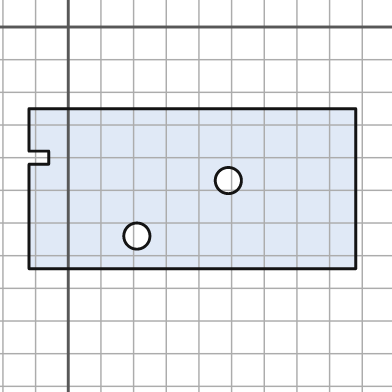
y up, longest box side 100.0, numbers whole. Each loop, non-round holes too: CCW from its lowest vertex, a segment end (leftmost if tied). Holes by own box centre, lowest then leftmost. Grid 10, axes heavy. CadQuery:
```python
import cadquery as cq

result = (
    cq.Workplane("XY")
    .moveTo(-12.0, -74.0)
    .lineTo(88.0, -74.0)
    .lineTo(88.0, -25.0)
    .lineTo(-12.0, -25.0)
    .lineTo(-12.0, -38.0)
    .lineTo(-6.0, -38.0)
    .lineTo(-6.0, -42.0)
    .lineTo(-12.0, -42.0)
    .close()
    .moveTo(21.0, -64.0)
    .circle(4.0)
    .moveTo(49.0, -47.0)
    .circle(4.0)
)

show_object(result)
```